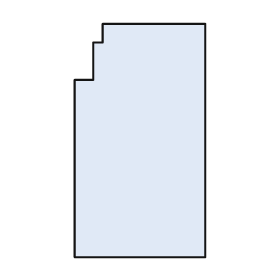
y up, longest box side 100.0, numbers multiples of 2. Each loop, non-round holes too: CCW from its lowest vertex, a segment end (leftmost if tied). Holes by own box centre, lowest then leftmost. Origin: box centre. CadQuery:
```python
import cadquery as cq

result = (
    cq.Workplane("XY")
    .moveTo(-28.0, -50.0)
    .lineTo(28.0, -50.0)
    .lineTo(28.0, 50.0)
    .lineTo(-16.0, 50.0)
    .lineTo(-16.0, 42.0)
    .lineTo(-20.0, 42.0)
    .lineTo(-20.0, 26.0)
    .lineTo(-28.0, 26.0)
    .close()
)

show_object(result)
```